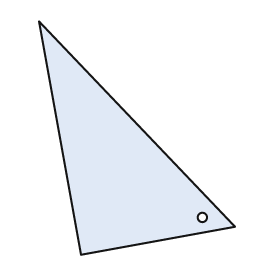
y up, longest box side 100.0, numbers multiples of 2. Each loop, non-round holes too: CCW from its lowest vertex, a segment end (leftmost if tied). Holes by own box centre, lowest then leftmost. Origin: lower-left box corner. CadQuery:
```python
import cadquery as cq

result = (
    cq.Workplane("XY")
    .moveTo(18.0, 0.0)
    .lineTo(84.0, 12.0)
    .lineTo(0.0, 100.0)
    .close()
    .moveTo(70.0, 16.0)
    .circle(2.0)
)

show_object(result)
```